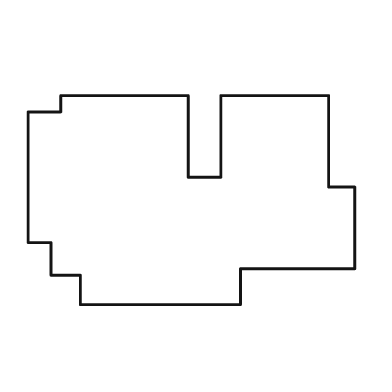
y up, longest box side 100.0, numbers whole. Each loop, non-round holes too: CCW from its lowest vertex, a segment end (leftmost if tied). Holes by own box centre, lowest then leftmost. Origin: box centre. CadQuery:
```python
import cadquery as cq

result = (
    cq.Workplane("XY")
    .moveTo(-34.0, -32.0)
    .lineTo(15.0, -32.0)
    .lineTo(15.0, -21.0)
    .lineTo(50.0, -21.0)
    .lineTo(50.0, 4.0)
    .lineTo(42.0, 4.0)
    .lineTo(42.0, 32.0)
    .lineTo(9.0, 32.0)
    .lineTo(9.0, 7.0)
    .lineTo(-1.0, 7.0)
    .lineTo(-1.0, 32.0)
    .lineTo(-40.0, 32.0)
    .lineTo(-40.0, 27.0)
    .lineTo(-50.0, 27.0)
    .lineTo(-50.0, -13.0)
    .lineTo(-43.0, -13.0)
    .lineTo(-43.0, -23.0)
    .lineTo(-34.0, -23.0)
    .close()
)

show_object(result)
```